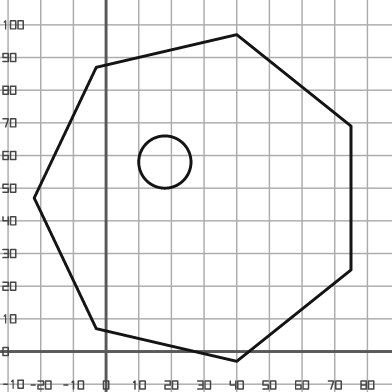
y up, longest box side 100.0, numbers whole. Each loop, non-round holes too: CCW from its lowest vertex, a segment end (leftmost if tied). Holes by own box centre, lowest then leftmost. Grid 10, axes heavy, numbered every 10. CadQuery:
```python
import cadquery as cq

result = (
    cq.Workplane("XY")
    .moveTo(40.0, -3.0)
    .lineTo(75.0, 25.0)
    .lineTo(75.0, 69.0)
    .lineTo(40.0, 97.0)
    .lineTo(-3.0, 87.0)
    .lineTo(-22.0, 47.0)
    .lineTo(-3.0, 7.0)
    .close()
    .moveTo(18.0, 58.0)
    .circle(8.0)
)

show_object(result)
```